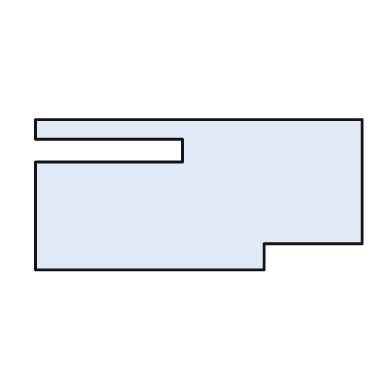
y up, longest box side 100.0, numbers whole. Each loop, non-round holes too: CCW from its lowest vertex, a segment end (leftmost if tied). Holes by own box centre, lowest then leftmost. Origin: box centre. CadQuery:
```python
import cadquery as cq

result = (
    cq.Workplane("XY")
    .moveTo(-50.0, -23.0)
    .lineTo(20.0, -23.0)
    .lineTo(20.0, -15.0)
    .lineTo(50.0, -15.0)
    .lineTo(50.0, 23.0)
    .lineTo(-50.0, 23.0)
    .lineTo(-50.0, 17.0)
    .lineTo(-5.0, 17.0)
    .lineTo(-5.0, 10.0)
    .lineTo(-50.0, 10.0)
    .close()
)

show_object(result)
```